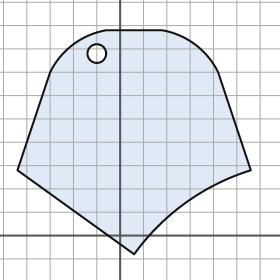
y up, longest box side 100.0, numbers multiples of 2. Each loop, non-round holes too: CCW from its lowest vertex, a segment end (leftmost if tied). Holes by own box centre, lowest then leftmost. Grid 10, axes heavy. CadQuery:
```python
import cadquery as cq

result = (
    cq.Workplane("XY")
    .moveTo(6.0, -8.0)
    .threePointArc((28.0, 14.0), (56.0, 28.0))
    .lineTo(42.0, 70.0)
    .threePointArc((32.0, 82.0), (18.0, 88.0))
    .lineTo(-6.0, 88.0)
    .threePointArc((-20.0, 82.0), (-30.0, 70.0))
    .lineTo(-44.0, 28.0)
    .close()
    .moveTo(-10.0, 78.0)
    .circle(4.0)
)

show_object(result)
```